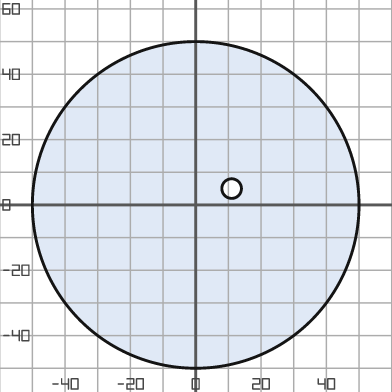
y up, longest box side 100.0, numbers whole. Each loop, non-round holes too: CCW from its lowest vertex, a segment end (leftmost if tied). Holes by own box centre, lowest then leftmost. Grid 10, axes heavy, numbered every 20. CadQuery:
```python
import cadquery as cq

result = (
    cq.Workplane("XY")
    .moveTo(0.0, 0.0)
    .circle(50.0)
    .moveTo(11.0, 5.0)
    .circle(3.0)
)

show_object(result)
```